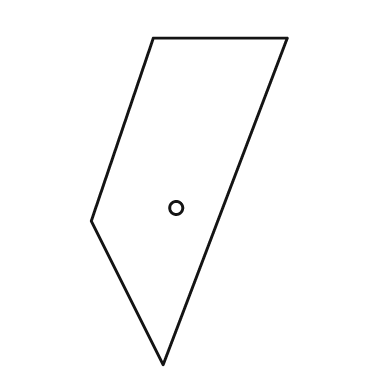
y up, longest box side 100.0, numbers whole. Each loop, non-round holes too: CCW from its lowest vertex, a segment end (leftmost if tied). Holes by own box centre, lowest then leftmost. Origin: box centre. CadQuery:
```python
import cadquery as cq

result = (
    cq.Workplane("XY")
    .moveTo(-8.0, -50.0)
    .lineTo(30.0, 50.0)
    .lineTo(-11.0, 50.0)
    .lineTo(-30.0, -6.0)
    .close()
    .moveTo(-4.0, -2.0)
    .circle(2.0)
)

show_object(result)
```